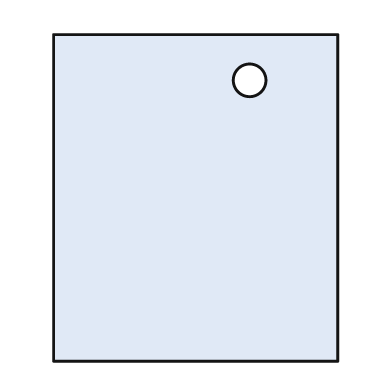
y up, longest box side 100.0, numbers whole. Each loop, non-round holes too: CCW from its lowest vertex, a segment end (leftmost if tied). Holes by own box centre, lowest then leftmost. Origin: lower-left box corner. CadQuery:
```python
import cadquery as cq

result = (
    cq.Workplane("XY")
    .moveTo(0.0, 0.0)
    .lineTo(87.0, 0.0)
    .lineTo(87.0, 100.0)
    .lineTo(0.0, 100.0)
    .close()
    .moveTo(60.0, 86.0)
    .circle(5.0)
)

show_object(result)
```